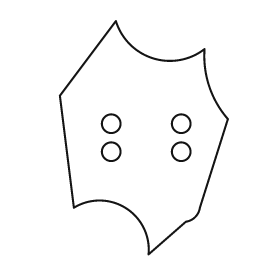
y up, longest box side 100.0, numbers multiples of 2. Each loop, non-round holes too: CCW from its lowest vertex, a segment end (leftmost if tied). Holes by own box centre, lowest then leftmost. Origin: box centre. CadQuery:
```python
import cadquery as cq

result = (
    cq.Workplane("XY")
    .moveTo(2.0, -50.0)
    .lineTo(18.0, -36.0)
    .threePointArc((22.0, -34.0), (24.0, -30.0))
    .lineTo(36.0, 8.0)
    .threePointArc((28.0, 22.0), (26.0, 38.0))
    .threePointArc((4.0, 34.0), (-12.0, 50.0))
    .lineTo(-36.0, 18.0)
    .lineTo(-30.0, -30.0)
    .threePointArc((-8.0, -30.0), (2.0, -50.0))
    .close()
    .moveTo(-14.0, -6.0)
    .circle(4.0)
    .moveTo(16.0, -6.0)
    .circle(4.0)
    .moveTo(-14.0, 6.0)
    .circle(4.0)
    .moveTo(16.0, 6.0)
    .circle(4.0)
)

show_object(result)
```